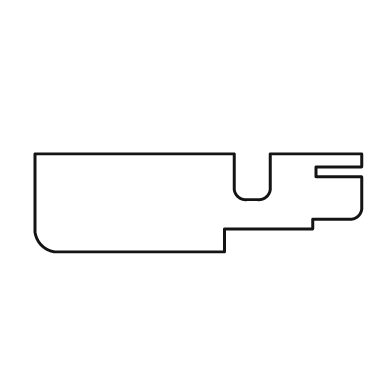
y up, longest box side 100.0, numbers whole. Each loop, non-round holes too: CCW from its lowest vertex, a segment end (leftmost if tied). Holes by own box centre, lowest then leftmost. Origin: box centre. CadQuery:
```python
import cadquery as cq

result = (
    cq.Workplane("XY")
    .moveTo(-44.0, -15.0)
    .lineTo(8.0, -15.0)
    .lineTo(8.0, -8.0)
    .lineTo(35.0, -8.0)
    .lineTo(35.0, -5.0)
    .lineTo(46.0, -5.0)
    .threePointArc((49.0, -4.0), (50.0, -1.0))
    .lineTo(50.0, 8.0)
    .lineTo(36.0, 8.0)
    .lineTo(36.0, 11.0)
    .lineTo(50.0, 11.0)
    .lineTo(50.0, 15.0)
    .lineTo(22.0, 15.0)
    .lineTo(22.0, 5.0)
    .threePointArc((21.0, 2.0), (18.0, 1.0))
    .lineTo(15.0, 1.0)
    .threePointArc((12.0, 2.0), (11.0, 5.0))
    .lineTo(11.0, 15.0)
    .lineTo(-50.0, 15.0)
    .lineTo(-50.0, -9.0)
    .threePointArc((-48.0, -13.0), (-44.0, -15.0))
    .close()
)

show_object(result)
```